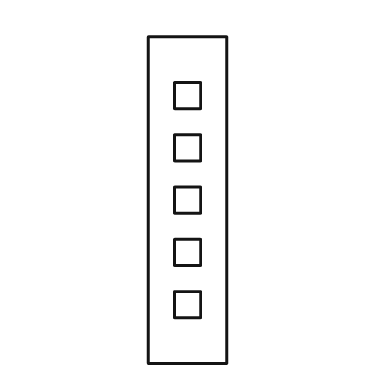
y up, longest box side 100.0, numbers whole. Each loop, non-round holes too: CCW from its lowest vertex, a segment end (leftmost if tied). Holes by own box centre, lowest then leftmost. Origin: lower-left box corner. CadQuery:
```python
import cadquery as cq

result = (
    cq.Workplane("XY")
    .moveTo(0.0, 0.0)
    .lineTo(24.0, 0.0)
    .lineTo(24.0, 100.0)
    .lineTo(0.0, 100.0)
    .close()
    .moveTo(8.0, 14.0)
    .lineTo(16.0, 14.0)
    .lineTo(16.0, 22.0)
    .lineTo(8.0, 22.0)
    .close()
    .moveTo(8.0, 30.0)
    .lineTo(16.0, 30.0)
    .lineTo(16.0, 38.0)
    .lineTo(8.0, 38.0)
    .close()
    .moveTo(8.0, 46.0)
    .lineTo(16.0, 46.0)
    .lineTo(16.0, 54.0)
    .lineTo(8.0, 54.0)
    .close()
    .moveTo(8.0, 62.0)
    .lineTo(16.0, 62.0)
    .lineTo(16.0, 70.0)
    .lineTo(8.0, 70.0)
    .close()
    .moveTo(8.0, 78.0)
    .lineTo(16.0, 78.0)
    .lineTo(16.0, 86.0)
    .lineTo(8.0, 86.0)
    .close()
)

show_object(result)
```